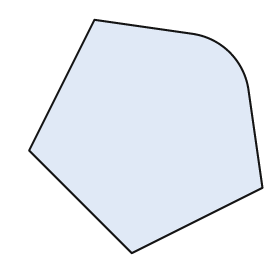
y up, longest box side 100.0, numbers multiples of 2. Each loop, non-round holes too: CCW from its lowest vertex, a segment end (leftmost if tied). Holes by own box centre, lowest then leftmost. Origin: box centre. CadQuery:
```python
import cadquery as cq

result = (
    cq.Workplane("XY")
    .moveTo(-6.0, -50.0)
    .lineTo(50.0, -22.0)
    .lineTo(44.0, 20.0)
    .threePointArc((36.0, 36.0), (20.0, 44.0))
    .lineTo(-22.0, 50.0)
    .lineTo(-50.0, -6.0)
    .close()
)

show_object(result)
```